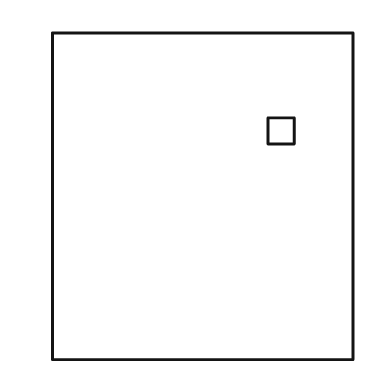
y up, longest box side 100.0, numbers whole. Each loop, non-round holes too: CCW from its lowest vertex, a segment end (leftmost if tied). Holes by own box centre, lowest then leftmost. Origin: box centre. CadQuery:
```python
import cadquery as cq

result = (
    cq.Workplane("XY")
    .moveTo(-46.0, -50.0)
    .lineTo(46.0, -50.0)
    .lineTo(46.0, 50.0)
    .lineTo(-46.0, 50.0)
    .close()
    .moveTo(20.0, 16.0)
    .lineTo(28.0, 16.0)
    .lineTo(28.0, 24.0)
    .lineTo(20.0, 24.0)
    .close()
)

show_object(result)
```